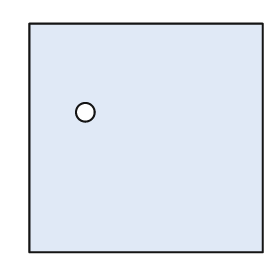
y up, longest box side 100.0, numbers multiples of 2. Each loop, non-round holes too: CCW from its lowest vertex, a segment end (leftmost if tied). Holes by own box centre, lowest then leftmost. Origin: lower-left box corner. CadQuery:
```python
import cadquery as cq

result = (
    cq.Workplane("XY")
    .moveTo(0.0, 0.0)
    .lineTo(100.0, 0.0)
    .lineTo(100.0, 98.0)
    .lineTo(0.0, 98.0)
    .close()
    .moveTo(24.0, 60.0)
    .circle(4.0)
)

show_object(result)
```